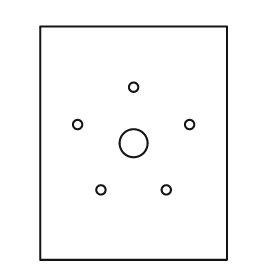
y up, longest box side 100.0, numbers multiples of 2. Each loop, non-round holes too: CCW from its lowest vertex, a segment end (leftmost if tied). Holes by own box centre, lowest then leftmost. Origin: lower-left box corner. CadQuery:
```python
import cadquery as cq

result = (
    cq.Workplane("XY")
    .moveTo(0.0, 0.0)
    .lineTo(80.0, 0.0)
    .lineTo(80.0, 100.0)
    .lineTo(0.0, 100.0)
    .close()
    .moveTo(26.0, 30.0)
    .circle(2.0)
    .moveTo(54.0, 30.0)
    .circle(2.0)
    .moveTo(40.0, 50.0)
    .circle(6.0)
    .moveTo(16.0, 58.0)
    .circle(2.0)
    .moveTo(64.0, 58.0)
    .circle(2.0)
    .moveTo(40.0, 74.0)
    .circle(2.0)
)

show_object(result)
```